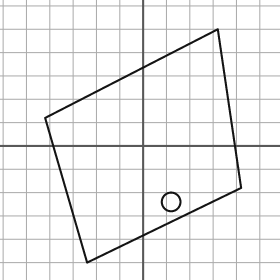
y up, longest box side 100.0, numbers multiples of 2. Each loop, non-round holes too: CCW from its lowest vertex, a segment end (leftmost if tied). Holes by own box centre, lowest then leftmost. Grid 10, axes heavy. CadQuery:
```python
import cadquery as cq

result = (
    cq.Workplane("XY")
    .moveTo(-24.0, -50.0)
    .lineTo(42.0, -18.0)
    .lineTo(32.0, 50.0)
    .lineTo(-42.0, 12.0)
    .close()
    .moveTo(12.0, -24.0)
    .circle(4.0)
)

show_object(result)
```